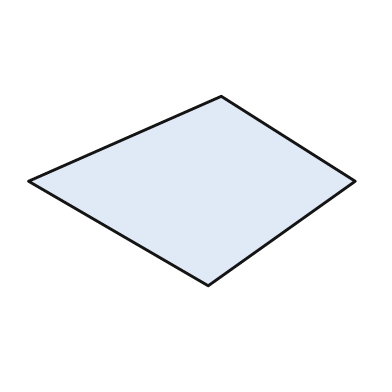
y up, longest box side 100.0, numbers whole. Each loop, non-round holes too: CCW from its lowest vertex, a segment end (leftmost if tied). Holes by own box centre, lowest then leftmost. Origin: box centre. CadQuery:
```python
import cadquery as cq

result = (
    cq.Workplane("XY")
    .moveTo(5.0, -29.0)
    .lineTo(50.0, 3.0)
    .lineTo(9.0, 29.0)
    .lineTo(-50.0, 3.0)
    .close()
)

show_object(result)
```